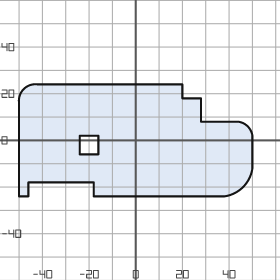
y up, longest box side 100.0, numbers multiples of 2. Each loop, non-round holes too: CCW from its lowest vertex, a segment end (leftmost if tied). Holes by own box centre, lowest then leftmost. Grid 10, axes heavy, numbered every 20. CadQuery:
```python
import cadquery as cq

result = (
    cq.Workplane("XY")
    .moveTo(-50.0, -24.0)
    .lineTo(-46.0, -24.0)
    .lineTo(-46.0, -18.0)
    .lineTo(-18.0, -18.0)
    .lineTo(-18.0, -24.0)
    .lineTo(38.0, -24.0)
    .threePointArc((46.0, -20.0), (50.0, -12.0))
    .lineTo(50.0, 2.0)
    .threePointArc((48.0, 6.0), (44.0, 8.0))
    .lineTo(28.0, 8.0)
    .lineTo(28.0, 18.0)
    .lineTo(20.0, 18.0)
    .lineTo(20.0, 24.0)
    .lineTo(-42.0, 24.0)
    .threePointArc((-48.0, 22.0), (-50.0, 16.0))
    .close()
    .moveTo(-24.0, -6.0)
    .lineTo(-16.0, -6.0)
    .lineTo(-16.0, 2.0)
    .lineTo(-24.0, 2.0)
    .close()
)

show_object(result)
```